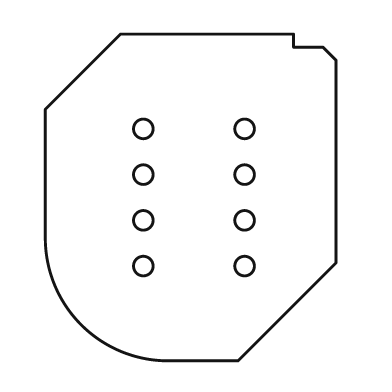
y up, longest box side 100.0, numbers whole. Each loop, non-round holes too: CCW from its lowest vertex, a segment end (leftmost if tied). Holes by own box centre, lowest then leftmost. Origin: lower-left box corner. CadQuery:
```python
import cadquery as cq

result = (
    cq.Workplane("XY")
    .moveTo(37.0, 0.0)
    .lineTo(59.0, 0.0)
    .lineTo(89.0, 30.0)
    .lineTo(89.0, 92.0)
    .lineTo(85.0, 96.0)
    .lineTo(76.0, 96.0)
    .lineTo(76.0, 100.0)
    .lineTo(23.0, 100.0)
    .lineTo(0.0, 77.0)
    .lineTo(0.0, 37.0)
    .threePointArc((11.0, 11.0), (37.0, 0.0))
    .close()
    .moveTo(30.0, 29.0)
    .circle(3.0)
    .moveTo(61.0, 29.0)
    .circle(3.0)
    .moveTo(30.0, 43.0)
    .circle(3.0)
    .moveTo(61.0, 43.0)
    .circle(3.0)
    .moveTo(30.0, 57.0)
    .circle(3.0)
    .moveTo(61.0, 57.0)
    .circle(3.0)
    .moveTo(30.0, 71.0)
    .circle(3.0)
    .moveTo(61.0, 71.0)
    .circle(3.0)
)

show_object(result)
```